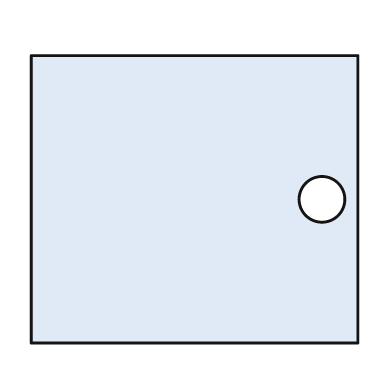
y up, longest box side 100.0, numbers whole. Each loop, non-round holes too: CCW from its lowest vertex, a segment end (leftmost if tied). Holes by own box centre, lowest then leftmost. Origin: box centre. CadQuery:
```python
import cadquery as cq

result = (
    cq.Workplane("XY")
    .moveTo(-50.0, -44.0)
    .lineTo(50.0, -44.0)
    .lineTo(50.0, 44.0)
    .lineTo(-50.0, 44.0)
    .close()
    .moveTo(39.0, 0.0)
    .circle(7.0)
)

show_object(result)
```